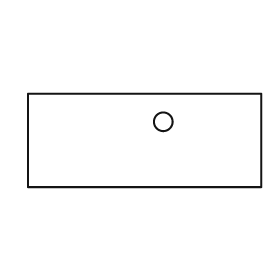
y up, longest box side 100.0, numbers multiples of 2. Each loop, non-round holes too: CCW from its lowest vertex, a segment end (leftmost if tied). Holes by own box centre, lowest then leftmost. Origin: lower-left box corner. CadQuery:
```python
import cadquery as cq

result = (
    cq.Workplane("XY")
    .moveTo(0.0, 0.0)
    .lineTo(100.0, 0.0)
    .lineTo(100.0, 40.0)
    .lineTo(0.0, 40.0)
    .close()
    .moveTo(58.0, 28.0)
    .circle(4.0)
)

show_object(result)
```